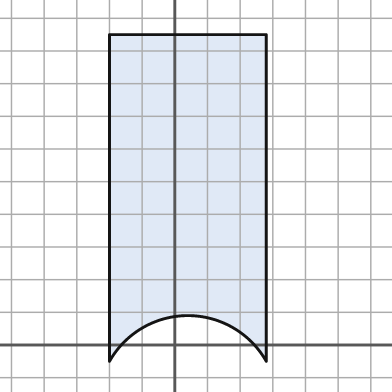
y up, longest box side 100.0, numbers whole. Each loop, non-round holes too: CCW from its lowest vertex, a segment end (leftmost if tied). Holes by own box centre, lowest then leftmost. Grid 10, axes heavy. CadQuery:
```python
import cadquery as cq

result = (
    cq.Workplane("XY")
    .moveTo(-20.0, -5.0)
    .threePointArc((4.0, 9.0), (28.0, -5.0))
    .lineTo(28.0, 95.0)
    .lineTo(-20.0, 95.0)
    .close()
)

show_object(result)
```